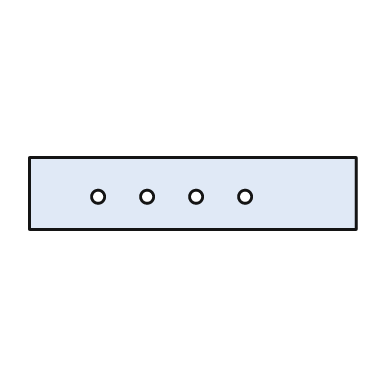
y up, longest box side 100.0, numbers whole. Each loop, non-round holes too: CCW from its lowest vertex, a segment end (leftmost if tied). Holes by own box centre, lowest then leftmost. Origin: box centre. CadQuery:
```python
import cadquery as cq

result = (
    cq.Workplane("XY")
    .moveTo(-50.0, -11.0)
    .lineTo(50.0, -11.0)
    .lineTo(50.0, 11.0)
    .lineTo(-50.0, 11.0)
    .close()
    .moveTo(-29.0, -1.0)
    .circle(2.0)
    .moveTo(-14.0, -1.0)
    .circle(2.0)
    .moveTo(1.0, -1.0)
    .circle(2.0)
    .moveTo(16.0, -1.0)
    .circle(2.0)
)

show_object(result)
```